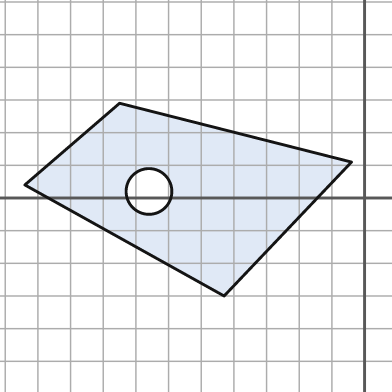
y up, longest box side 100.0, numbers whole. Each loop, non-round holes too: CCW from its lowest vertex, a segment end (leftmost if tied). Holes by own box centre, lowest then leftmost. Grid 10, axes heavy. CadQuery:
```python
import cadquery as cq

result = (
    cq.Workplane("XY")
    .moveTo(-43.0, -30.0)
    .lineTo(-4.0, 11.0)
    .lineTo(-75.0, 29.0)
    .lineTo(-104.0, 4.0)
    .close()
    .moveTo(-66.0, 2.0)
    .circle(7.0)
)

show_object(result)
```